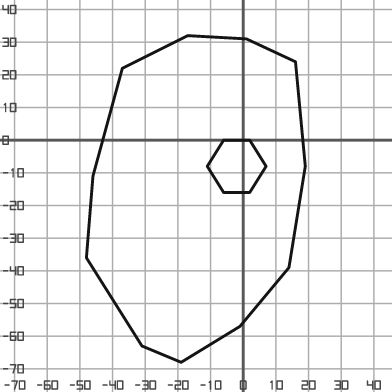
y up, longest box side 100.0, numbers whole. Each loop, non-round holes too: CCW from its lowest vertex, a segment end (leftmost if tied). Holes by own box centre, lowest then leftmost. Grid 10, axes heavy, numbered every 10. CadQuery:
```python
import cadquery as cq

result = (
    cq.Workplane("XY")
    .moveTo(-19.0, -68.0)
    .lineTo(-1.0, -57.0)
    .lineTo(14.0, -39.0)
    .lineTo(19.0, -8.0)
    .lineTo(16.0, 24.0)
    .lineTo(1.0, 31.0)
    .lineTo(-17.0, 32.0)
    .lineTo(-37.0, 22.0)
    .lineTo(-46.0, -11.0)
    .lineTo(-48.0, -36.0)
    .lineTo(-31.0, -63.0)
    .close()
    .moveTo(-6.0, -16.0)
    .lineTo(2.0, -16.0)
    .lineTo(7.0, -8.0)
    .lineTo(2.0, 0.0)
    .lineTo(-6.0, 0.0)
    .lineTo(-11.0, -8.0)
    .close()
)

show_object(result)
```